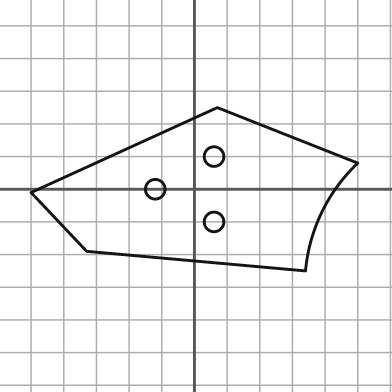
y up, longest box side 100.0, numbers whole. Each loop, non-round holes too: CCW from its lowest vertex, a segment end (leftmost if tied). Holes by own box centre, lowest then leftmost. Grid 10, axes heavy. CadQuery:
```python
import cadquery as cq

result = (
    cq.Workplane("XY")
    .moveTo(34.0, -25.0)
    .threePointArc((39.0, -7.0), (50.0, 8.0))
    .lineTo(7.0, 25.0)
    .lineTo(-50.0, -1.0)
    .lineTo(-33.0, -19.0)
    .close()
    .moveTo(6.0, -10.0)
    .circle(3.0)
    .moveTo(-12.0, 0.0)
    .circle(3.0)
    .moveTo(6.0, 10.0)
    .circle(3.0)
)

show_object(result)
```